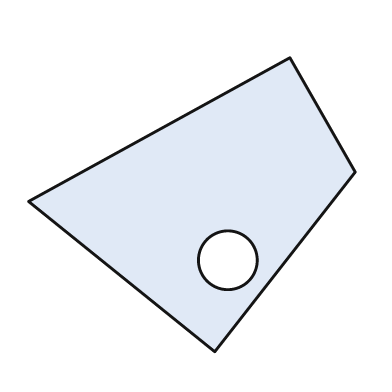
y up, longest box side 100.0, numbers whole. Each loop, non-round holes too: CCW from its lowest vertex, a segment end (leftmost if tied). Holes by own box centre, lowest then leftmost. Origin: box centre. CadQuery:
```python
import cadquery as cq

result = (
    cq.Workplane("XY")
    .moveTo(7.0, -45.0)
    .lineTo(50.0, 10.0)
    .lineTo(30.0, 45.0)
    .lineTo(-50.0, 1.0)
    .close()
    .moveTo(11.0, -17.0)
    .circle(9.0)
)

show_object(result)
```